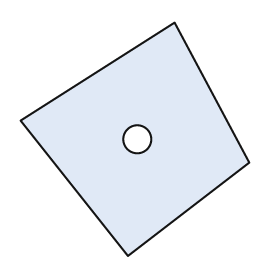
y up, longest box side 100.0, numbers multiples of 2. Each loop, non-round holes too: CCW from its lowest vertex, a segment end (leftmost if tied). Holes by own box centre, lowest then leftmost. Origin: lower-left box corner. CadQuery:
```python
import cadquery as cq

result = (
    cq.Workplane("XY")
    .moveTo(46.0, 0.0)
    .lineTo(98.0, 40.0)
    .lineTo(66.0, 100.0)
    .lineTo(0.0, 58.0)
    .close()
    .moveTo(50.0, 50.0)
    .circle(6.0)
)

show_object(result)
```